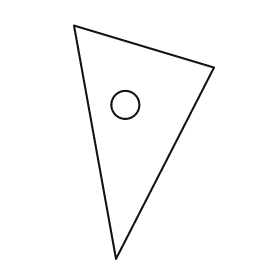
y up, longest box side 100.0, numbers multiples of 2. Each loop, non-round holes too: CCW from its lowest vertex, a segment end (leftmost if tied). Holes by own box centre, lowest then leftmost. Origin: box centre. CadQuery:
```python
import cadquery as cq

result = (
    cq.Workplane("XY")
    .moveTo(-12.0, -50.0)
    .lineTo(30.0, 32.0)
    .lineTo(-30.0, 50.0)
    .close()
    .moveTo(-8.0, 16.0)
    .circle(6.0)
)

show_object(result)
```